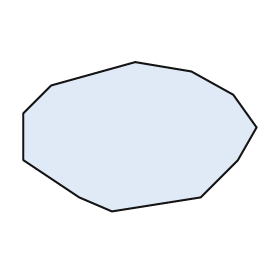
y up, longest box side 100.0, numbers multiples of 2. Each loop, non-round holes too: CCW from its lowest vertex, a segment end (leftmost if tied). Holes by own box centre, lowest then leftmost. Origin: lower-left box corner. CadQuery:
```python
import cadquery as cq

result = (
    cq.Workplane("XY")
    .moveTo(38.0, 0.0)
    .lineTo(76.0, 6.0)
    .lineTo(92.0, 22.0)
    .lineTo(100.0, 36.0)
    .lineTo(90.0, 50.0)
    .lineTo(72.0, 60.0)
    .lineTo(48.0, 64.0)
    .lineTo(12.0, 54.0)
    .lineTo(0.0, 42.0)
    .lineTo(0.0, 22.0)
    .lineTo(24.0, 6.0)
    .close()
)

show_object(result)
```